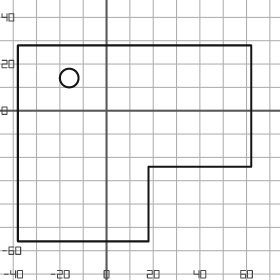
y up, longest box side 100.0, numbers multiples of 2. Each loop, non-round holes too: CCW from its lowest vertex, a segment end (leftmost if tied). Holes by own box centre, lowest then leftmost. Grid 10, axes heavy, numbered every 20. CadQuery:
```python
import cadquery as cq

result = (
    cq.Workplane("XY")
    .moveTo(-38.0, -56.0)
    .lineTo(18.0, -56.0)
    .lineTo(18.0, -24.0)
    .lineTo(62.0, -24.0)
    .lineTo(62.0, 28.0)
    .lineTo(-38.0, 28.0)
    .close()
    .moveTo(-16.0, 14.0)
    .circle(4.0)
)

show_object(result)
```